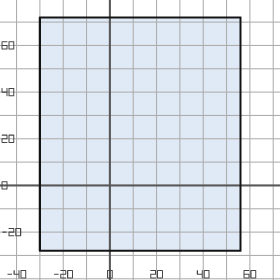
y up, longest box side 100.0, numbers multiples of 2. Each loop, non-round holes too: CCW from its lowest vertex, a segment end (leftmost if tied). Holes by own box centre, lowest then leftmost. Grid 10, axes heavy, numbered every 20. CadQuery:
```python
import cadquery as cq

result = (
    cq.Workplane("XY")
    .moveTo(-30.0, -28.0)
    .lineTo(56.0, -28.0)
    .lineTo(56.0, 72.0)
    .lineTo(-30.0, 72.0)
    .close()
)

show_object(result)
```